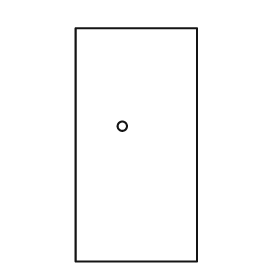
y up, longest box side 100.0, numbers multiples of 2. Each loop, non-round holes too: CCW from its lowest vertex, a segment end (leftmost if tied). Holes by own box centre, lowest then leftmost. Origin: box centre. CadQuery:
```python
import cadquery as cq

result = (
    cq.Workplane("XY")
    .moveTo(-26.0, -50.0)
    .lineTo(26.0, -50.0)
    .lineTo(26.0, 50.0)
    .lineTo(-26.0, 50.0)
    .close()
    .moveTo(-6.0, 8.0)
    .circle(2.0)
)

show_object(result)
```